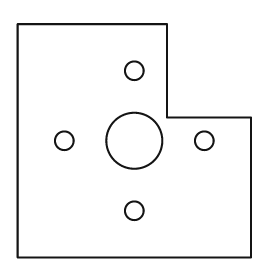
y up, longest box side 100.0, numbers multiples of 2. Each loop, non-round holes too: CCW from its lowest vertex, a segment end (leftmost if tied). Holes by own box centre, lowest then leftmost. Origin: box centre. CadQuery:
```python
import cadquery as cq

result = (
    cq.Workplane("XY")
    .moveTo(-50.0, -50.0)
    .lineTo(50.0, -50.0)
    .lineTo(50.0, 10.0)
    .lineTo(14.0, 10.0)
    .lineTo(14.0, 50.0)
    .lineTo(-50.0, 50.0)
    .close()
    .moveTo(0.0, -30.0)
    .circle(4.0)
    .moveTo(-30.0, 0.0)
    .circle(4.0)
    .moveTo(0.0, 0.0)
    .circle(12.0)
    .moveTo(30.0, 0.0)
    .circle(4.0)
    .moveTo(0.0, 30.0)
    .circle(4.0)
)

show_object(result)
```